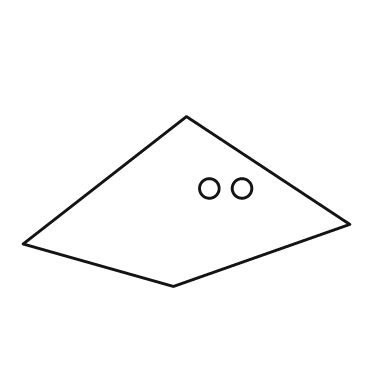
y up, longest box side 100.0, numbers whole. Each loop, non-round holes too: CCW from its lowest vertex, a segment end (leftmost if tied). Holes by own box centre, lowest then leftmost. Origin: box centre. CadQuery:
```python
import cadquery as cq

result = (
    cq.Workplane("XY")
    .moveTo(-4.0, -26.0)
    .lineTo(50.0, -7.0)
    .lineTo(0.0, 26.0)
    .lineTo(-50.0, -13.0)
    .close()
    .moveTo(7.0, 4.0)
    .circle(3.0)
    .moveTo(17.0, 4.0)
    .circle(3.0)
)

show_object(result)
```